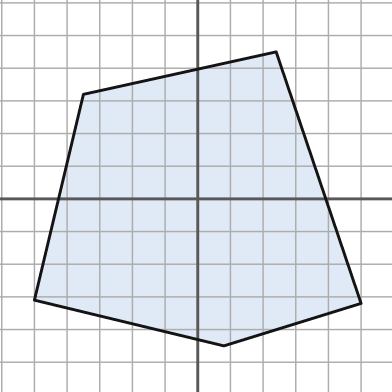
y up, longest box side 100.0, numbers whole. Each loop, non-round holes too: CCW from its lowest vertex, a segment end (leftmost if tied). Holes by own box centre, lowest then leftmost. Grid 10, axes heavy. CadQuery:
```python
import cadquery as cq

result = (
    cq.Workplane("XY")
    .moveTo(8.0, -45.0)
    .lineTo(50.0, -32.0)
    .lineTo(24.0, 45.0)
    .lineTo(-35.0, 32.0)
    .lineTo(-50.0, -31.0)
    .close()
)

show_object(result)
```